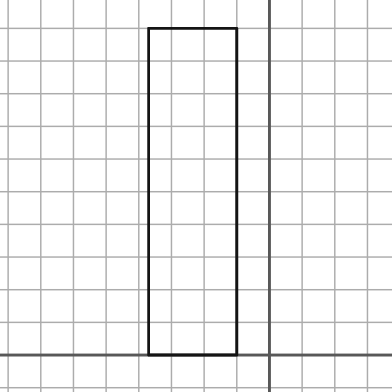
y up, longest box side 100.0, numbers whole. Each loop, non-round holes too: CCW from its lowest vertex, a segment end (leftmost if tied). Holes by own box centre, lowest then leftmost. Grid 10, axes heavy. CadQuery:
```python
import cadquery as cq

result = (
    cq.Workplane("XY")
    .moveTo(-37.0, 0.0)
    .lineTo(-10.0, 0.0)
    .lineTo(-10.0, 100.0)
    .lineTo(-37.0, 100.0)
    .close()
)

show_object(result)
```